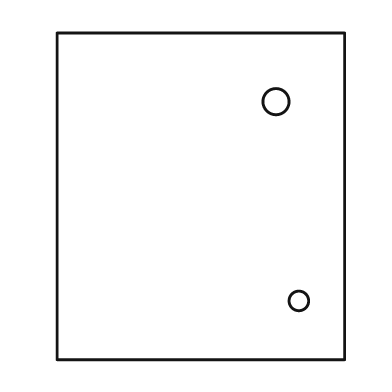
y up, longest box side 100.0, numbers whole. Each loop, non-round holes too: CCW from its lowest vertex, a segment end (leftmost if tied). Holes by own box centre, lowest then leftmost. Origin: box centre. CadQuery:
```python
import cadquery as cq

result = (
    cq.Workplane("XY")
    .moveTo(-44.0, -50.0)
    .lineTo(44.0, -50.0)
    .lineTo(44.0, 50.0)
    .lineTo(-44.0, 50.0)
    .close()
    .moveTo(30.0, -32.0)
    .circle(3.0)
    .moveTo(23.0, 29.0)
    .circle(4.0)
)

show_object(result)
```